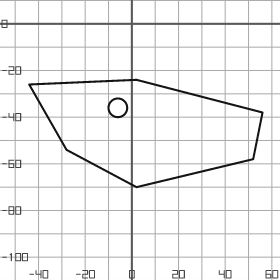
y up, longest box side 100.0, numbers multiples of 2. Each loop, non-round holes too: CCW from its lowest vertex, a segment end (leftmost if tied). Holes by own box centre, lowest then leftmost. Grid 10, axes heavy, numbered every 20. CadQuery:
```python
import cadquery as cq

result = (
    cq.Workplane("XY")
    .moveTo(2.0, -70.0)
    .lineTo(52.0, -58.0)
    .lineTo(56.0, -38.0)
    .lineTo(2.0, -24.0)
    .lineTo(-44.0, -26.0)
    .lineTo(-28.0, -54.0)
    .close()
    .moveTo(-6.0, -36.0)
    .circle(4.0)
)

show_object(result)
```